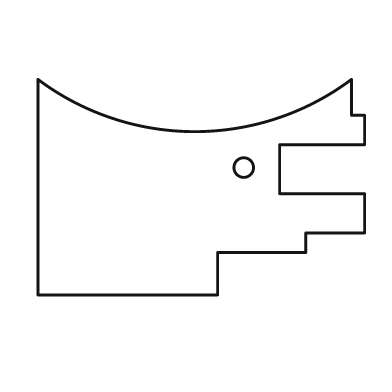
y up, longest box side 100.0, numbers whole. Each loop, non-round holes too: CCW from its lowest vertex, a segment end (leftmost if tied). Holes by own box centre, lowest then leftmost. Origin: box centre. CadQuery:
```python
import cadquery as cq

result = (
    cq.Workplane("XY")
    .moveTo(-50.0, -33.0)
    .lineTo(5.0, -33.0)
    .lineTo(5.0, -20.0)
    .lineTo(32.0, -20.0)
    .lineTo(32.0, -14.0)
    .lineTo(50.0, -14.0)
    .lineTo(50.0, -2.0)
    .lineTo(24.0, -2.0)
    .lineTo(24.0, 13.0)
    .lineTo(50.0, 13.0)
    .lineTo(50.0, 22.0)
    .lineTo(46.0, 22.0)
    .lineTo(46.0, 33.0)
    .threePointArc((-2.0, 17.0), (-50.0, 33.0))
    .close()
    .moveTo(13.0, 6.0)
    .circle(3.0)
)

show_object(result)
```